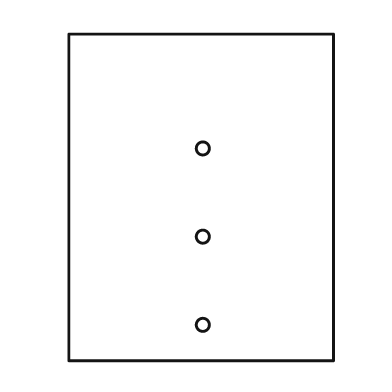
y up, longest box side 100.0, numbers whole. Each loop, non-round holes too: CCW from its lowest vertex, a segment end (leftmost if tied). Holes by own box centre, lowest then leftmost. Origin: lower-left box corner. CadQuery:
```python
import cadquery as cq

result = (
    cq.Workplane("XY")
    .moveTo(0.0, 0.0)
    .lineTo(81.0, 0.0)
    .lineTo(81.0, 100.0)
    .lineTo(0.0, 100.0)
    .close()
    .moveTo(41.0, 11.0)
    .circle(2.0)
    .moveTo(41.0, 38.0)
    .circle(2.0)
    .moveTo(41.0, 65.0)
    .circle(2.0)
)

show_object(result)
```